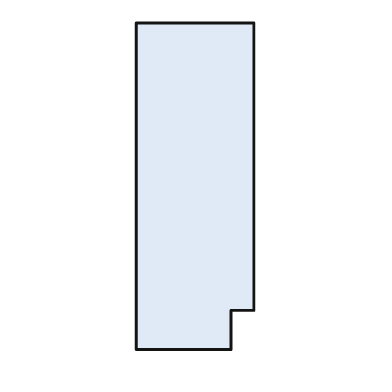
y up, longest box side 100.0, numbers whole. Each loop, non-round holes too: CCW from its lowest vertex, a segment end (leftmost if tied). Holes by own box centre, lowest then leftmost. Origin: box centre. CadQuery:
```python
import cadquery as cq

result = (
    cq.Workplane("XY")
    .moveTo(-18.0, -50.0)
    .lineTo(11.0, -50.0)
    .lineTo(11.0, -38.0)
    .lineTo(18.0, -38.0)
    .lineTo(18.0, 50.0)
    .lineTo(-18.0, 50.0)
    .close()
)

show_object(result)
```